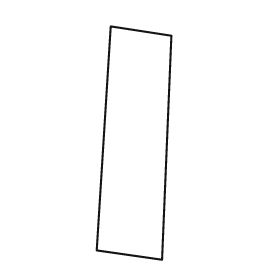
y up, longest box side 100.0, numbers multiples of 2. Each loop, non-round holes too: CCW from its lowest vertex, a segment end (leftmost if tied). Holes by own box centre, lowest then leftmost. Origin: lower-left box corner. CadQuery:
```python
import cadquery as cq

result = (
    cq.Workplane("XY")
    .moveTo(28.0, 0.0)
    .lineTo(32.0, 96.0)
    .lineTo(6.0, 100.0)
    .lineTo(0.0, 4.0)
    .close()
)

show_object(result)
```